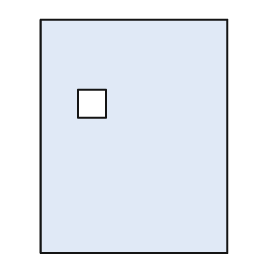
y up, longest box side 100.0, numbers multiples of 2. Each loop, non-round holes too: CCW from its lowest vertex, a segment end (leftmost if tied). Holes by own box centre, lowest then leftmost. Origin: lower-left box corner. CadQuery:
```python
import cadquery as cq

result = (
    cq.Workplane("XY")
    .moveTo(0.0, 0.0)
    .lineTo(80.0, 0.0)
    .lineTo(80.0, 100.0)
    .lineTo(0.0, 100.0)
    .close()
    .moveTo(16.0, 58.0)
    .lineTo(28.0, 58.0)
    .lineTo(28.0, 70.0)
    .lineTo(16.0, 70.0)
    .close()
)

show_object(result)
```